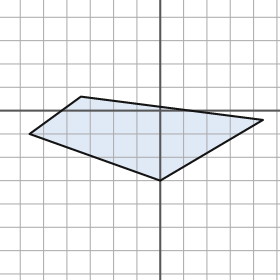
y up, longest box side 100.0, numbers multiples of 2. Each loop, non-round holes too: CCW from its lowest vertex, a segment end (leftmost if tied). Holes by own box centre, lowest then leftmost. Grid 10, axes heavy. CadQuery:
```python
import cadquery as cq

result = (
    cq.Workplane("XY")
    .moveTo(0.0, -30.0)
    .lineTo(44.0, -4.0)
    .lineTo(-34.0, 6.0)
    .lineTo(-56.0, -10.0)
    .close()
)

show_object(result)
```